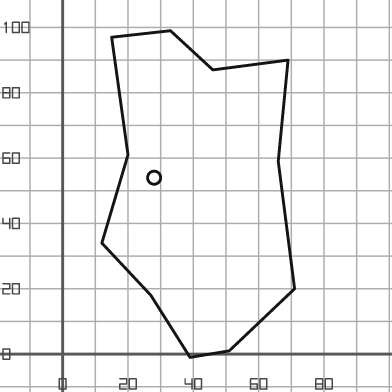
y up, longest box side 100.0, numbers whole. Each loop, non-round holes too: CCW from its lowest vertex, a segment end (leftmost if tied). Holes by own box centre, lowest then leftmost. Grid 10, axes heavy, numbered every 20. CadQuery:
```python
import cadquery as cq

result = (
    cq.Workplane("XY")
    .moveTo(39.0, -1.0)
    .lineTo(51.0, 1.0)
    .lineTo(71.0, 20.0)
    .lineTo(66.0, 59.0)
    .lineTo(69.0, 90.0)
    .lineTo(46.0, 87.0)
    .lineTo(33.0, 99.0)
    .lineTo(15.0, 97.0)
    .lineTo(20.0, 61.0)
    .lineTo(12.0, 34.0)
    .lineTo(27.0, 18.0)
    .close()
    .moveTo(28.0, 54.0)
    .circle(2.0)
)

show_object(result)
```